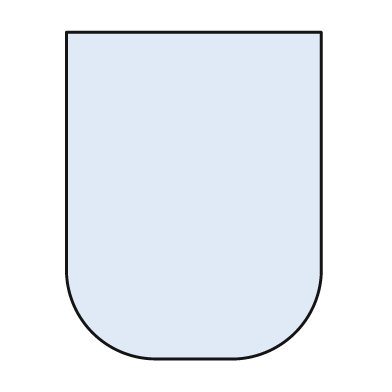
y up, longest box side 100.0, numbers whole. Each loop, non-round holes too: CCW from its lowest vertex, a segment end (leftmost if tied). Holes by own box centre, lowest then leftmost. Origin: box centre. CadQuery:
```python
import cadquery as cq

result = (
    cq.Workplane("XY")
    .moveTo(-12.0, -50.0)
    .lineTo(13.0, -50.0)
    .threePointArc((31.0, -42.0), (39.0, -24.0))
    .lineTo(39.0, 50.0)
    .lineTo(-39.0, 50.0)
    .lineTo(-39.0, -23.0)
    .threePointArc((-31.0, -42.0), (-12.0, -50.0))
    .close()
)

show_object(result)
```